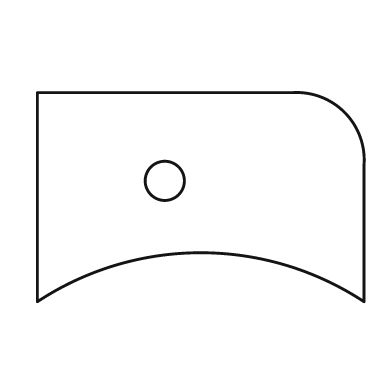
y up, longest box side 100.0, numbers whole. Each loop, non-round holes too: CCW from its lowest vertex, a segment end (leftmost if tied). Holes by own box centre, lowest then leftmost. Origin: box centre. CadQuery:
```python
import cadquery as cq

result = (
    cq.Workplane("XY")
    .moveTo(-50.0, -32.0)
    .threePointArc((0.0, -17.0), (50.0, -32.0))
    .lineTo(50.0, 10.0)
    .threePointArc((44.0, 26.0), (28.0, 32.0))
    .lineTo(-50.0, 32.0)
    .close()
    .moveTo(-11.0, 5.0)
    .circle(6.0)
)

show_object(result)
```